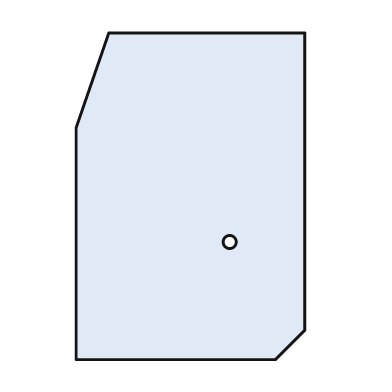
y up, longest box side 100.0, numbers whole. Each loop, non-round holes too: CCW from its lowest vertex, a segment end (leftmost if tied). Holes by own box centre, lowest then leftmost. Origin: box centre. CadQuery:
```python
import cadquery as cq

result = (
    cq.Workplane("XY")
    .moveTo(-35.0, -50.0)
    .lineTo(26.0, -50.0)
    .lineTo(35.0, -41.0)
    .lineTo(35.0, 50.0)
    .lineTo(-25.0, 50.0)
    .lineTo(-35.0, 21.0)
    .close()
    .moveTo(12.0, -14.0)
    .circle(2.0)
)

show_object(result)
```